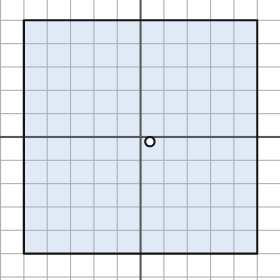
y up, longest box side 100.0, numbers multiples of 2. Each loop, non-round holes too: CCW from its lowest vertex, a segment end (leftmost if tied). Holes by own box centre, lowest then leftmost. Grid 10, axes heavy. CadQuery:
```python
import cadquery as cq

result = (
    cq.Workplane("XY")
    .moveTo(-50.0, -50.0)
    .lineTo(50.0, -50.0)
    .lineTo(50.0, 50.0)
    .lineTo(-50.0, 50.0)
    .close()
    .moveTo(4.0, -2.0)
    .circle(2.0)
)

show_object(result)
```